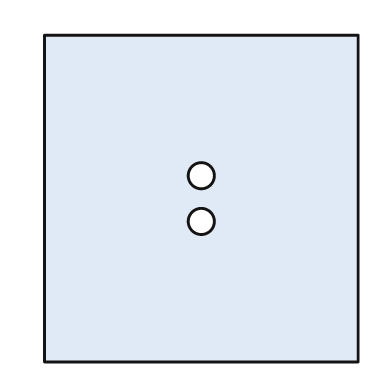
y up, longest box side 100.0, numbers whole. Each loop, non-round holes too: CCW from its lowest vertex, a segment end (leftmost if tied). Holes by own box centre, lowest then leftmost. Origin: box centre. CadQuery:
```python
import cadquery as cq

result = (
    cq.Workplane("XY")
    .moveTo(-48.0, -50.0)
    .lineTo(48.0, -50.0)
    .lineTo(48.0, 50.0)
    .lineTo(-48.0, 50.0)
    .close()
    .moveTo(0.0, -7.0)
    .circle(4.0)
    .moveTo(0.0, 7.0)
    .circle(4.0)
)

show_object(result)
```